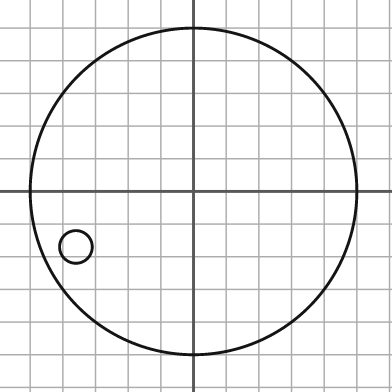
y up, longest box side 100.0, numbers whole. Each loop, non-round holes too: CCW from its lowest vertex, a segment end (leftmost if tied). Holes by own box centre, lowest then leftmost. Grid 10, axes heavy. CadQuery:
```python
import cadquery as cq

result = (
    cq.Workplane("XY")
    .moveTo(0.0, 0.0)
    .circle(50.0)
    .moveTo(-36.0, -17.0)
    .circle(5.0)
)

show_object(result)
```